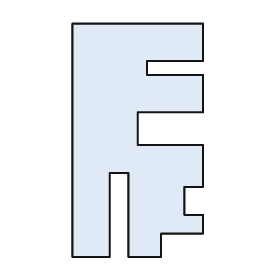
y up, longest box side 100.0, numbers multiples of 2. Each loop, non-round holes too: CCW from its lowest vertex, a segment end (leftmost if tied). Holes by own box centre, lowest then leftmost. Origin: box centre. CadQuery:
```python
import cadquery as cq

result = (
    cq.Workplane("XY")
    .moveTo(-28.0, -50.0)
    .lineTo(-12.0, -50.0)
    .lineTo(-12.0, -14.0)
    .lineTo(-4.0, -14.0)
    .lineTo(-4.0, -50.0)
    .lineTo(10.0, -50.0)
    .lineTo(10.0, -40.0)
    .lineTo(28.0, -40.0)
    .lineTo(28.0, -32.0)
    .lineTo(20.0, -32.0)
    .lineTo(20.0, -20.0)
    .lineTo(28.0, -20.0)
    .lineTo(28.0, -2.0)
    .lineTo(0.0, -2.0)
    .lineTo(0.0, 12.0)
    .lineTo(28.0, 12.0)
    .lineTo(28.0, 28.0)
    .lineTo(4.0, 28.0)
    .lineTo(4.0, 34.0)
    .lineTo(28.0, 34.0)
    .lineTo(28.0, 50.0)
    .lineTo(-28.0, 50.0)
    .close()
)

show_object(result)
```